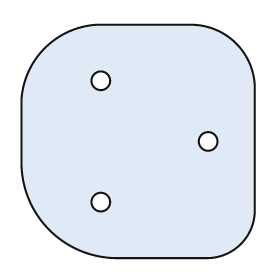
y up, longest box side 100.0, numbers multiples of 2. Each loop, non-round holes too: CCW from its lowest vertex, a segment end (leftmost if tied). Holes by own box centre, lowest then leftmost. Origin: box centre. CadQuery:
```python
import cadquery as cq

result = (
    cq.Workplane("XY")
    .moveTo(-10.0, -50.0)
    .lineTo(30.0, -50.0)
    .threePointArc((44.0, -44.0), (50.0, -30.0))
    .lineTo(50.0, 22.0)
    .threePointArc((42.0, 42.0), (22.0, 50.0))
    .lineTo(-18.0, 50.0)
    .threePointArc((-40.0, 40.0), (-50.0, 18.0))
    .lineTo(-50.0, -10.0)
    .threePointArc((-38.0, -38.0), (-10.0, -50.0))
    .close()
    .moveTo(-16.0, -26.0)
    .circle(4.0)
    .moveTo(30.0, 0.0)
    .circle(4.0)
    .moveTo(-16.0, 26.0)
    .circle(4.0)
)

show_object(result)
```